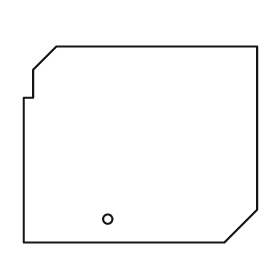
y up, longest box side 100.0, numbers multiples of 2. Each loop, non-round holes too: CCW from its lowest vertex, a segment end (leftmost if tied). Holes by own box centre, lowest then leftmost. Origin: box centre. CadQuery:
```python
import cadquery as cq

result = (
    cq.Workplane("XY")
    .moveTo(-50.0, -42.0)
    .lineTo(36.0, -42.0)
    .lineTo(50.0, -28.0)
    .lineTo(50.0, 42.0)
    .lineTo(-36.0, 42.0)
    .lineTo(-46.0, 32.0)
    .lineTo(-46.0, 20.0)
    .lineTo(-50.0, 20.0)
    .close()
    .moveTo(-14.0, -32.0)
    .circle(2.0)
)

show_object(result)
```